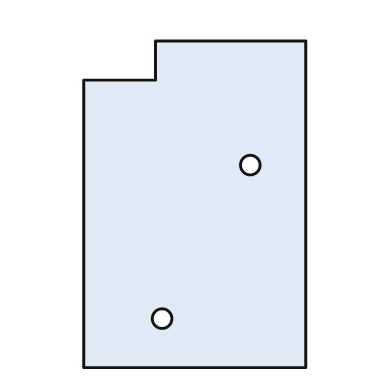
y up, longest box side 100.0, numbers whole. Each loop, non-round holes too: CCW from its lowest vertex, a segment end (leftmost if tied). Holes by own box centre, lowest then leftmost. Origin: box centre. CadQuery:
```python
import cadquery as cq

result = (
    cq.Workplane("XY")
    .moveTo(-34.0, -50.0)
    .lineTo(34.0, -50.0)
    .lineTo(34.0, 50.0)
    .lineTo(-12.0, 50.0)
    .lineTo(-12.0, 38.0)
    .lineTo(-34.0, 38.0)
    .close()
    .moveTo(-10.0, -35.0)
    .circle(3.0)
    .moveTo(17.0, 12.0)
    .circle(3.0)
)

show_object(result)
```